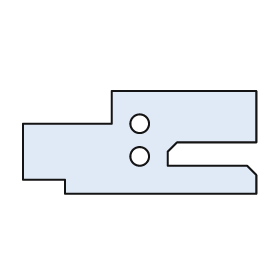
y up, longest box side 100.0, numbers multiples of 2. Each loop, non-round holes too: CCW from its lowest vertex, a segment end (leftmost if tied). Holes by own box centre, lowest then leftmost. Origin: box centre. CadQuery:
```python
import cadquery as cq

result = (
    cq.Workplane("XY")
    .moveTo(-32.0, -22.0)
    .lineTo(50.0, -22.0)
    .lineTo(50.0, -14.0)
    .lineTo(46.0, -10.0)
    .lineTo(12.0, -10.0)
    .lineTo(12.0, -4.0)
    .lineTo(16.0, 0.0)
    .lineTo(50.0, 0.0)
    .lineTo(50.0, 22.0)
    .lineTo(-12.0, 22.0)
    .lineTo(-12.0, 8.0)
    .lineTo(-50.0, 8.0)
    .lineTo(-50.0, -16.0)
    .lineTo(-32.0, -16.0)
    .close()
    .moveTo(0.0, -6.0)
    .circle(4.0)
    .moveTo(0.0, 8.0)
    .circle(4.0)
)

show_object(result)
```